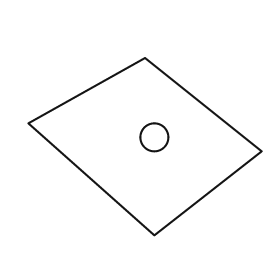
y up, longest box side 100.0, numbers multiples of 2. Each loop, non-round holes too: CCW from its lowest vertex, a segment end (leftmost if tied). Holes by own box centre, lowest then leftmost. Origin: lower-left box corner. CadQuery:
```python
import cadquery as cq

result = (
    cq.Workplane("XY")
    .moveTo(54.0, 0.0)
    .lineTo(100.0, 36.0)
    .lineTo(50.0, 76.0)
    .lineTo(0.0, 48.0)
    .close()
    .moveTo(54.0, 42.0)
    .circle(6.0)
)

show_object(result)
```